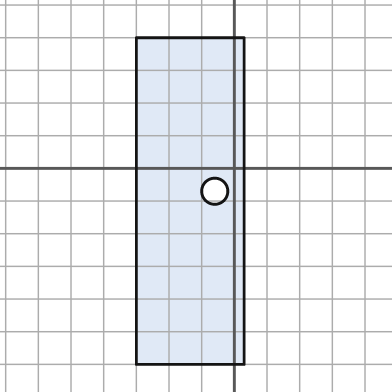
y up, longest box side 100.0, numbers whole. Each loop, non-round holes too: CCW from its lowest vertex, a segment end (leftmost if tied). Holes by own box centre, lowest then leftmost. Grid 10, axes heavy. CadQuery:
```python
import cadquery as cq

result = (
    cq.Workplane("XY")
    .moveTo(-30.0, -60.0)
    .lineTo(3.0, -60.0)
    .lineTo(3.0, 40.0)
    .lineTo(-30.0, 40.0)
    .close()
    .moveTo(-6.0, -7.0)
    .circle(4.0)
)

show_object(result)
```